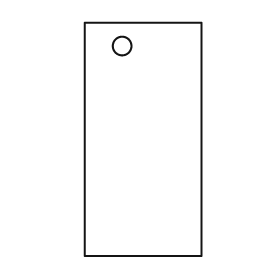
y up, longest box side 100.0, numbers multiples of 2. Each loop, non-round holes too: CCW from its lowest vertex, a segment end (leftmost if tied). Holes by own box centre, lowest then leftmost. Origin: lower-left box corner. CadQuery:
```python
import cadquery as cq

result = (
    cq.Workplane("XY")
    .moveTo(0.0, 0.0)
    .lineTo(50.0, 0.0)
    .lineTo(50.0, 100.0)
    .lineTo(0.0, 100.0)
    .close()
    .moveTo(16.0, 90.0)
    .circle(4.0)
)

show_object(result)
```